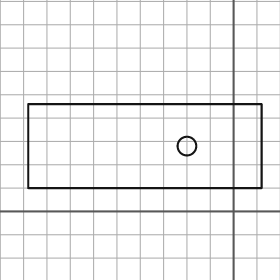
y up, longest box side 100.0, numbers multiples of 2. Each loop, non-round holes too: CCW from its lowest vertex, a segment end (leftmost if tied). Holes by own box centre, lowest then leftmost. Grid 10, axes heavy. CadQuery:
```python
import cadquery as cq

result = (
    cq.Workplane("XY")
    .moveTo(-88.0, 10.0)
    .lineTo(12.0, 10.0)
    .lineTo(12.0, 46.0)
    .lineTo(-88.0, 46.0)
    .close()
    .moveTo(-20.0, 28.0)
    .circle(4.0)
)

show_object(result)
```